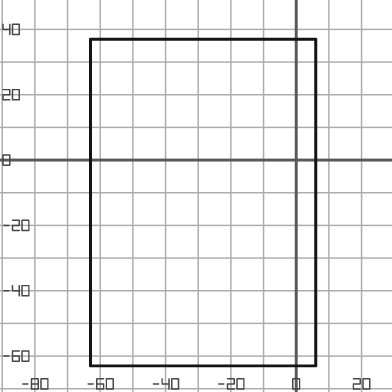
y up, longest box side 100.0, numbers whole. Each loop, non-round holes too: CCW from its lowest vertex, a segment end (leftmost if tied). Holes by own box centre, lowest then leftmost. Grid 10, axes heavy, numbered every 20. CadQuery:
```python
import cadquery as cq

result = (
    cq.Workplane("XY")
    .moveTo(-63.0, -63.0)
    .lineTo(6.0, -63.0)
    .lineTo(6.0, 37.0)
    .lineTo(-63.0, 37.0)
    .close()
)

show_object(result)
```